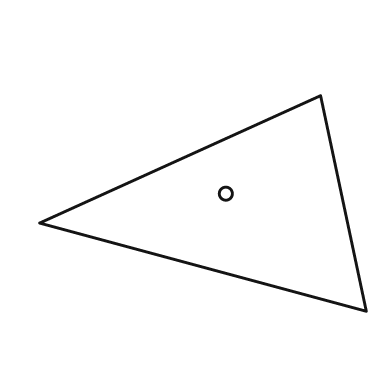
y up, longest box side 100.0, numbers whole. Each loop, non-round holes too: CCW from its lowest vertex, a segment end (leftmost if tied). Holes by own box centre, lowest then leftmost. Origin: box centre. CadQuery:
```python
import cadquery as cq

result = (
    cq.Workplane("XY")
    .moveTo(50.0, -33.0)
    .lineTo(36.0, 33.0)
    .lineTo(-50.0, -6.0)
    .close()
    .moveTo(7.0, 3.0)
    .circle(2.0)
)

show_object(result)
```